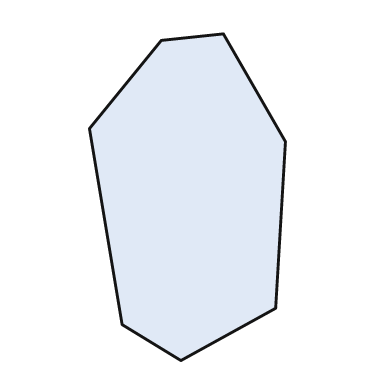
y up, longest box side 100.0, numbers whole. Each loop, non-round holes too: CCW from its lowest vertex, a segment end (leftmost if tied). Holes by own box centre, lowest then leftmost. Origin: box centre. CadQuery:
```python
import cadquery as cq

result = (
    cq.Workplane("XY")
    .moveTo(-2.0, -50.0)
    .lineTo(27.0, -34.0)
    .lineTo(30.0, 17.0)
    .lineTo(11.0, 50.0)
    .lineTo(-8.0, 48.0)
    .lineTo(-30.0, 21.0)
    .lineTo(-20.0, -39.0)
    .close()
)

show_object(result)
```